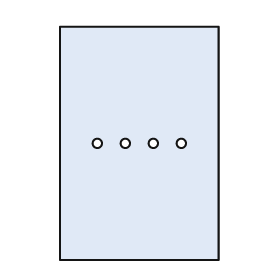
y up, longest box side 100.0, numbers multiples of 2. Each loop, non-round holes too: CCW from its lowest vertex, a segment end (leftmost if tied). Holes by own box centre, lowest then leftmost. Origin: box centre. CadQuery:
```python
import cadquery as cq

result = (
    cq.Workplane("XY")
    .moveTo(-34.0, -50.0)
    .lineTo(34.0, -50.0)
    .lineTo(34.0, 50.0)
    .lineTo(-34.0, 50.0)
    .close()
    .moveTo(-18.0, 0.0)
    .circle(2.0)
    .moveTo(-6.0, 0.0)
    .circle(2.0)
    .moveTo(6.0, 0.0)
    .circle(2.0)
    .moveTo(18.0, 0.0)
    .circle(2.0)
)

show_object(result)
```